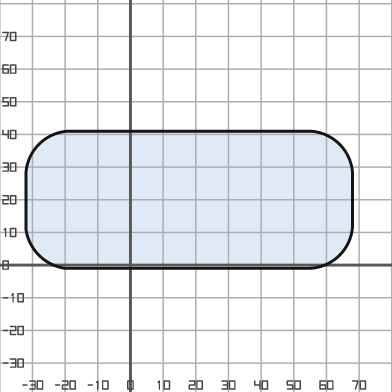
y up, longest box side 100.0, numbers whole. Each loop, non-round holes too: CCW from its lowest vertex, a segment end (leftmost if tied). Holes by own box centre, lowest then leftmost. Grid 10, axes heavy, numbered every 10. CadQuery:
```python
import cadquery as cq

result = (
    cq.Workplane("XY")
    .moveTo(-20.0, -1.0)
    .lineTo(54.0, -1.0)
    .threePointArc((64.0, 3.0), (68.0, 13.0))
    .lineTo(68.0, 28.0)
    .threePointArc((64.0, 37.0), (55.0, 41.0))
    .lineTo(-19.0, 41.0)
    .threePointArc((-28.0, 37.0), (-32.0, 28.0))
    .lineTo(-32.0, 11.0)
    .threePointArc((-28.0, 3.0), (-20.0, -1.0))
    .close()
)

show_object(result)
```